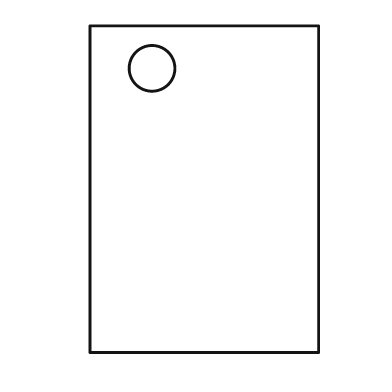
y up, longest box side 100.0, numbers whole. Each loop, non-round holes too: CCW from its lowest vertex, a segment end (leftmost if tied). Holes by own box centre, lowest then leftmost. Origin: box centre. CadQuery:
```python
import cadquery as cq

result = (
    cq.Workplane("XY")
    .moveTo(-35.0, -50.0)
    .lineTo(35.0, -50.0)
    .lineTo(35.0, 50.0)
    .lineTo(-35.0, 50.0)
    .close()
    .moveTo(-16.0, 37.0)
    .circle(7.0)
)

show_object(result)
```